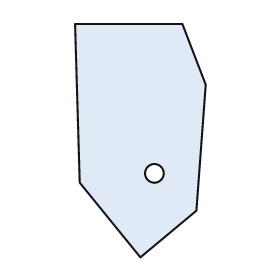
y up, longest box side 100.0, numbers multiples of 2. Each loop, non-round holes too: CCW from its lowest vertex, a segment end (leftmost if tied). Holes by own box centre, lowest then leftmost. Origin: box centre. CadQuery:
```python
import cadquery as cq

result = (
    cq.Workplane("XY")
    .moveTo(0.0, -50.0)
    .lineTo(24.0, -30.0)
    .lineTo(28.0, 24.0)
    .lineTo(18.0, 50.0)
    .lineTo(-28.0, 50.0)
    .lineTo(-26.0, -18.0)
    .close()
    .moveTo(6.0, -14.0)
    .circle(4.0)
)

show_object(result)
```